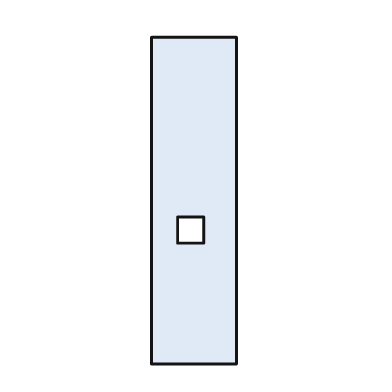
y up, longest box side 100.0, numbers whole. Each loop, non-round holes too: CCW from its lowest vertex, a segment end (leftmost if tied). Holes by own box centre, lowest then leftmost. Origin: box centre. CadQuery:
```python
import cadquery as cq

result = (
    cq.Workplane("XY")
    .moveTo(-13.0, -50.0)
    .lineTo(13.0, -50.0)
    .lineTo(13.0, 50.0)
    .lineTo(-13.0, 50.0)
    .close()
    .moveTo(-5.0, -13.0)
    .lineTo(3.0, -13.0)
    .lineTo(3.0, -5.0)
    .lineTo(-5.0, -5.0)
    .close()
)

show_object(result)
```